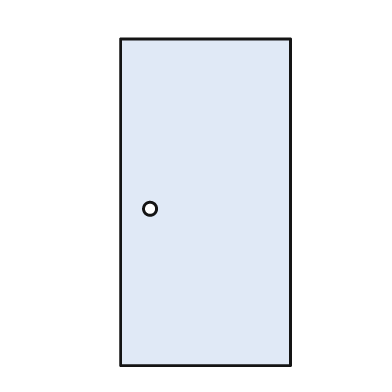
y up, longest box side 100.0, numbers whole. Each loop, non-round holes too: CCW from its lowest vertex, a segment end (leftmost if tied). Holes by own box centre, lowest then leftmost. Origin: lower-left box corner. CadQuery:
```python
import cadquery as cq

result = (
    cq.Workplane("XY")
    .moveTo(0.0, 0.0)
    .lineTo(52.0, 0.0)
    .lineTo(52.0, 100.0)
    .lineTo(0.0, 100.0)
    .close()
    .moveTo(9.0, 48.0)
    .circle(2.0)
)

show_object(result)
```